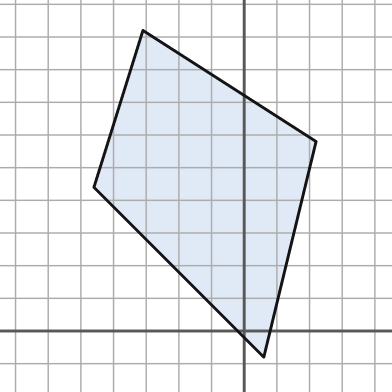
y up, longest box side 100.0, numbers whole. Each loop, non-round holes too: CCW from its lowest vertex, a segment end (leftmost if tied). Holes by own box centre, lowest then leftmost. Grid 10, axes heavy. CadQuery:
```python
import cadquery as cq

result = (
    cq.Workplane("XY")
    .moveTo(6.0, -8.0)
    .lineTo(22.0, 58.0)
    .lineTo(-31.0, 92.0)
    .lineTo(-46.0, 44.0)
    .close()
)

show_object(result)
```